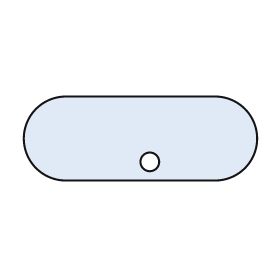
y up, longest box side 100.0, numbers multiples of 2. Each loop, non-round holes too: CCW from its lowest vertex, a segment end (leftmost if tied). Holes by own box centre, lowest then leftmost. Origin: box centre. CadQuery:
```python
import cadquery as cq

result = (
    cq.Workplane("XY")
    .moveTo(-32.0, -18.0)
    .lineTo(32.0, -18.0)
    .threePointArc((50.0, 0.0), (32.0, 18.0))
    .lineTo(-32.0, 18.0)
    .threePointArc((-50.0, 0.0), (-32.0, -18.0))
    .close()
    .moveTo(4.0, -10.0)
    .circle(4.0)
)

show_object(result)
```